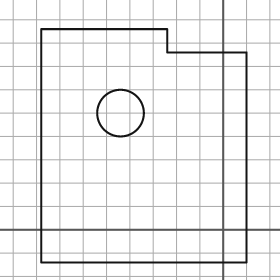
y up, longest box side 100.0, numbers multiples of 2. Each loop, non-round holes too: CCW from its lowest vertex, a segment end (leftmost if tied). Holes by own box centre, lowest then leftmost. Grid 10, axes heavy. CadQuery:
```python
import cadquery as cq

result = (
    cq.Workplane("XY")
    .moveTo(-78.0, -14.0)
    .lineTo(10.0, -14.0)
    .lineTo(10.0, 76.0)
    .lineTo(-24.0, 76.0)
    .lineTo(-24.0, 86.0)
    .lineTo(-78.0, 86.0)
    .close()
    .moveTo(-44.0, 50.0)
    .circle(10.0)
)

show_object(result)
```